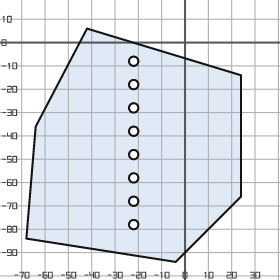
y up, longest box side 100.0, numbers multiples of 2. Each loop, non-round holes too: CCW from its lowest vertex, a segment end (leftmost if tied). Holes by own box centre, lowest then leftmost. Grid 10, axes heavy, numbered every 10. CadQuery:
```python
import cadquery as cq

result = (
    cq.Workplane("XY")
    .moveTo(-4.0, -94.0)
    .lineTo(24.0, -66.0)
    .lineTo(24.0, -14.0)
    .lineTo(-42.0, 6.0)
    .lineTo(-64.0, -36.0)
    .lineTo(-68.0, -84.0)
    .close()
    .moveTo(-22.0, -78.0)
    .circle(2.0)
    .moveTo(-22.0, -68.0)
    .circle(2.0)
    .moveTo(-22.0, -58.0)
    .circle(2.0)
    .moveTo(-22.0, -48.0)
    .circle(2.0)
    .moveTo(-22.0, -38.0)
    .circle(2.0)
    .moveTo(-22.0, -28.0)
    .circle(2.0)
    .moveTo(-22.0, -18.0)
    .circle(2.0)
    .moveTo(-22.0, -8.0)
    .circle(2.0)
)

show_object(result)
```